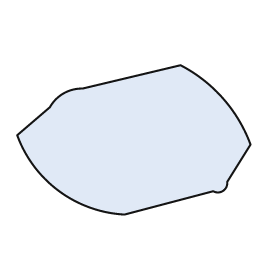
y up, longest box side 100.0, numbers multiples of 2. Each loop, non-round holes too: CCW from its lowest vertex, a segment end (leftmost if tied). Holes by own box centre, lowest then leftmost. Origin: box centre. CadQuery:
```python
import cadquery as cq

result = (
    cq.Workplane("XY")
    .moveTo(-4.0, -32.0)
    .lineTo(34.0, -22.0)
    .threePointArc((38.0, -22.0), (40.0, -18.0))
    .lineTo(50.0, -2.0)
    .threePointArc((38.0, 18.0), (20.0, 32.0))
    .lineTo(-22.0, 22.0)
    .threePointArc((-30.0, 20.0), (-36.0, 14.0))
    .lineTo(-50.0, 2.0)
    .threePointArc((-32.0, -22.0), (-4.0, -32.0))
    .close()
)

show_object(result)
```